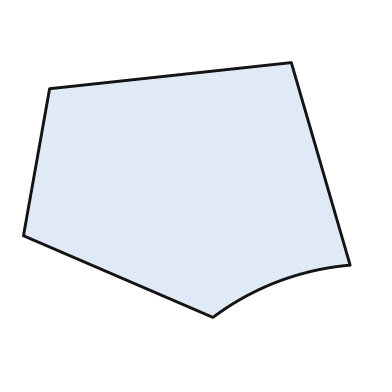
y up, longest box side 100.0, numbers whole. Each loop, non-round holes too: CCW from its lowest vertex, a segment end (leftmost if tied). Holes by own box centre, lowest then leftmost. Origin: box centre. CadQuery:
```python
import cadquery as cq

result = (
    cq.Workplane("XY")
    .moveTo(8.0, -39.0)
    .threePointArc((28.0, -28.0), (50.0, -23.0))
    .lineTo(32.0, 39.0)
    .lineTo(-42.0, 31.0)
    .lineTo(-50.0, -14.0)
    .close()
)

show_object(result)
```